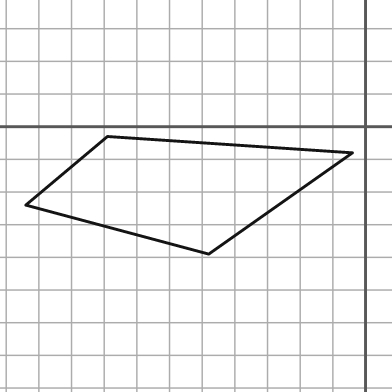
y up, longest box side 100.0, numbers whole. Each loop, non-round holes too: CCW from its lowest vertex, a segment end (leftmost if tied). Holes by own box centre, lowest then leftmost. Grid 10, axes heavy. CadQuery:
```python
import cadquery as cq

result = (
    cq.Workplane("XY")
    .moveTo(-48.0, -39.0)
    .lineTo(-4.0, -8.0)
    .lineTo(-79.0, -3.0)
    .lineTo(-104.0, -24.0)
    .close()
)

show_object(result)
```